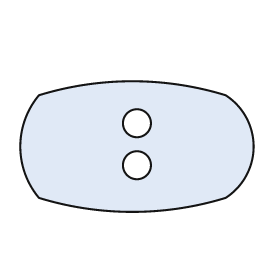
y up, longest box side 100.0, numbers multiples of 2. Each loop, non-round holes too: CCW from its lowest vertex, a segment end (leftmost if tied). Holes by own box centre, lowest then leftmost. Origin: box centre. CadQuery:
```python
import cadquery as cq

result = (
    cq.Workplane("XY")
    .moveTo(-42.0, -22.0)
    .threePointArc((-2.0, -28.0), (38.0, -22.0))
    .threePointArc((50.0, 0.0), (38.0, 22.0))
    .threePointArc((-2.0, 28.0), (-42.0, 22.0))
    .threePointArc((-50.0, 0.0), (-42.0, -22.0))
    .close()
    .moveTo(0.0, -8.0)
    .circle(6.0)
    .moveTo(0.0, 10.0)
    .circle(6.0)
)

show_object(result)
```